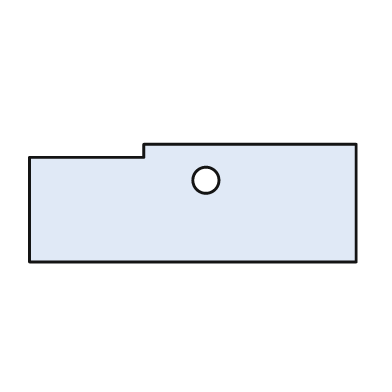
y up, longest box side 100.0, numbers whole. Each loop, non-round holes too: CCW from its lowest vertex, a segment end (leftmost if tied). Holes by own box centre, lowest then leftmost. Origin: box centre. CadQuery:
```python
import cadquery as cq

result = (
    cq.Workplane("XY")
    .moveTo(-50.0, -18.0)
    .lineTo(50.0, -18.0)
    .lineTo(50.0, 18.0)
    .lineTo(-15.0, 18.0)
    .lineTo(-15.0, 14.0)
    .lineTo(-50.0, 14.0)
    .close()
    .moveTo(4.0, 7.0)
    .circle(4.0)
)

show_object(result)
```